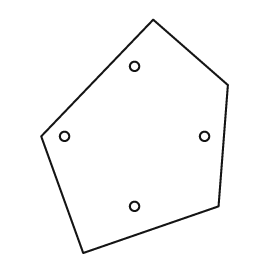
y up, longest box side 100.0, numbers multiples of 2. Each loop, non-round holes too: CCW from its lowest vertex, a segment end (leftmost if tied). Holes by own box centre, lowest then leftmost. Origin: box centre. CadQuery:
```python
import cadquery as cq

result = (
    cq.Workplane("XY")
    .moveTo(-22.0, -50.0)
    .lineTo(36.0, -30.0)
    .lineTo(40.0, 22.0)
    .lineTo(8.0, 50.0)
    .lineTo(-40.0, 0.0)
    .close()
    .moveTo(0.0, -30.0)
    .circle(2.0)
    .moveTo(-30.0, 0.0)
    .circle(2.0)
    .moveTo(30.0, 0.0)
    .circle(2.0)
    .moveTo(0.0, 30.0)
    .circle(2.0)
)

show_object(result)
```